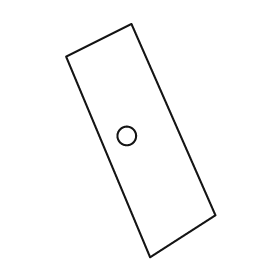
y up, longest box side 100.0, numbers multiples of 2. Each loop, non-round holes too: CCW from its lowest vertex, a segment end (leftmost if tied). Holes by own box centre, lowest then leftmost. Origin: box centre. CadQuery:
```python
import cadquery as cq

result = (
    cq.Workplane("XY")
    .moveTo(4.0, -50.0)
    .lineTo(32.0, -32.0)
    .lineTo(-4.0, 50.0)
    .lineTo(-32.0, 36.0)
    .close()
    .moveTo(-6.0, 2.0)
    .circle(4.0)
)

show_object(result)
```